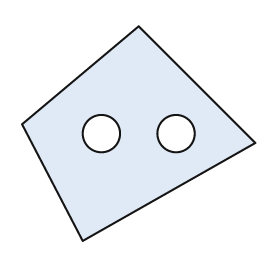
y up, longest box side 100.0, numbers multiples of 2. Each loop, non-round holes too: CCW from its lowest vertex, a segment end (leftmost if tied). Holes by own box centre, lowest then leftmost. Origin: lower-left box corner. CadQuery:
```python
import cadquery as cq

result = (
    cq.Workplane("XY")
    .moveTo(26.0, 0.0)
    .lineTo(100.0, 42.0)
    .lineTo(50.0, 92.0)
    .lineTo(0.0, 50.0)
    .close()
    .moveTo(34.0, 46.0)
    .circle(8.0)
    .moveTo(66.0, 46.0)
    .circle(8.0)
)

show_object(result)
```